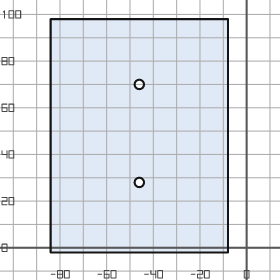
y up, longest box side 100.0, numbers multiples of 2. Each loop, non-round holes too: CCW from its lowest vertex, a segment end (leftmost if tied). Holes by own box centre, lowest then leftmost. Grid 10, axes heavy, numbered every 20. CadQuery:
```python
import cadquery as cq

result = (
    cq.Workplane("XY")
    .moveTo(-84.0, -2.0)
    .lineTo(-8.0, -2.0)
    .lineTo(-8.0, 98.0)
    .lineTo(-84.0, 98.0)
    .close()
    .moveTo(-46.0, 28.0)
    .circle(2.0)
    .moveTo(-46.0, 70.0)
    .circle(2.0)
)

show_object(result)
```